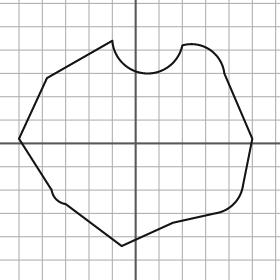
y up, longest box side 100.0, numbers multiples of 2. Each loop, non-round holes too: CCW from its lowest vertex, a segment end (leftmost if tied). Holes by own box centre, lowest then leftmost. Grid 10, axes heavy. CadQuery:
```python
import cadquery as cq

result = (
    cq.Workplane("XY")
    .moveTo(-6.0, -44.0)
    .lineTo(16.0, -34.0)
    .lineTo(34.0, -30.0)
    .threePointArc((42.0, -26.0), (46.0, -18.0))
    .lineTo(50.0, 2.0)
    .lineTo(38.0, 30.0)
    .threePointArc((32.0, 40.0), (20.0, 42.0))
    .threePointArc((4.0, 30.0), (-10.0, 44.0))
    .lineTo(-38.0, 28.0)
    .lineTo(-50.0, 2.0)
    .lineTo(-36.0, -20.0)
    .threePointArc((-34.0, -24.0), (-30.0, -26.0))
    .close()
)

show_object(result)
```